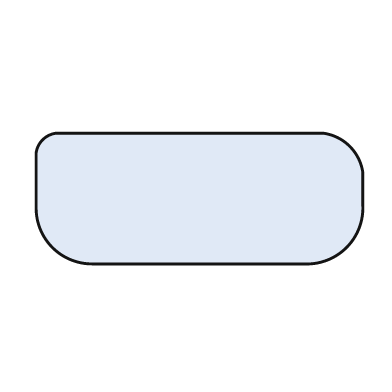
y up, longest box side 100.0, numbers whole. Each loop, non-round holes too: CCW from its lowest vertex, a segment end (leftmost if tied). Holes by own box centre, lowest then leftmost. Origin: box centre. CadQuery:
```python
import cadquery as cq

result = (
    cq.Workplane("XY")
    .moveTo(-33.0, -20.0)
    .lineTo(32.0, -20.0)
    .threePointArc((45.0, -15.0), (50.0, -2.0))
    .lineTo(50.0, 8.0)
    .threePointArc((46.0, 16.0), (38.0, 20.0))
    .lineTo(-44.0, 20.0)
    .threePointArc((-48.0, 18.0), (-50.0, 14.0))
    .lineTo(-50.0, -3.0)
    .threePointArc((-45.0, -15.0), (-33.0, -20.0))
    .close()
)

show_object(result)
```